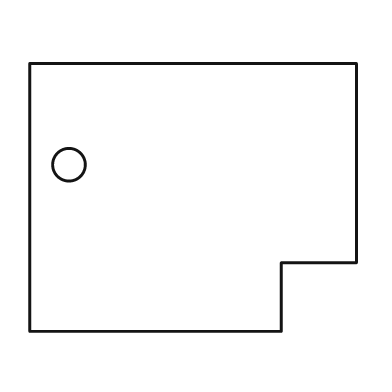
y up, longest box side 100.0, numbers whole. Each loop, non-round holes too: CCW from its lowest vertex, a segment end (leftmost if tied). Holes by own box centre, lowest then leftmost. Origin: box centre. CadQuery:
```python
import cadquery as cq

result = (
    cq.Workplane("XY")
    .moveTo(-50.0, -41.0)
    .lineTo(27.0, -41.0)
    .lineTo(27.0, -20.0)
    .lineTo(50.0, -20.0)
    .lineTo(50.0, 41.0)
    .lineTo(-50.0, 41.0)
    .close()
    .moveTo(-38.0, 10.0)
    .circle(5.0)
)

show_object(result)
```